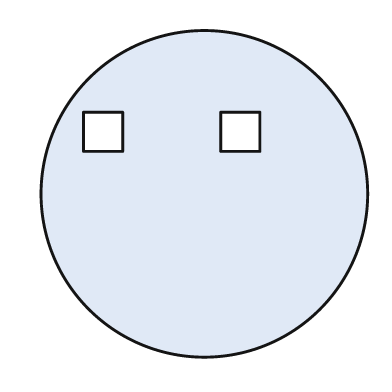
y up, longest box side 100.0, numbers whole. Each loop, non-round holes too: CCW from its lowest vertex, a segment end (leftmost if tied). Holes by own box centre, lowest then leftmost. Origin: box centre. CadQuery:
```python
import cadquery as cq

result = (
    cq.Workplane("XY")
    .moveTo(0.0, 0.0)
    .circle(50.0)
    .moveTo(-37.0, 13.0)
    .lineTo(-25.0, 13.0)
    .lineTo(-25.0, 25.0)
    .lineTo(-37.0, 25.0)
    .close()
    .moveTo(5.0, 13.0)
    .lineTo(17.0, 13.0)
    .lineTo(17.0, 25.0)
    .lineTo(5.0, 25.0)
    .close()
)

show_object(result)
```